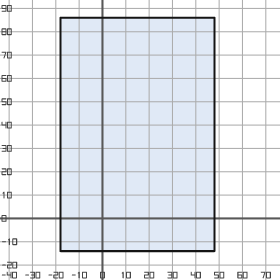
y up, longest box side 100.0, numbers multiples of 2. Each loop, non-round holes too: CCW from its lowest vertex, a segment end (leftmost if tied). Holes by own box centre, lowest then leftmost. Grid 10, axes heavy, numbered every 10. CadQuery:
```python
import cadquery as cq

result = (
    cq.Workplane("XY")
    .moveTo(-18.0, -14.0)
    .lineTo(48.0, -14.0)
    .lineTo(48.0, 86.0)
    .lineTo(-18.0, 86.0)
    .close()
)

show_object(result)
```